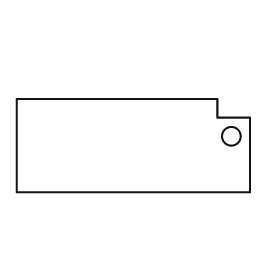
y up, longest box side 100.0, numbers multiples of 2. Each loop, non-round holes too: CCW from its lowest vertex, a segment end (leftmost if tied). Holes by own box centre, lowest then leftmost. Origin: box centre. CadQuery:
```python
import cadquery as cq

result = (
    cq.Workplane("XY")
    .moveTo(-50.0, -20.0)
    .lineTo(50.0, -20.0)
    .lineTo(50.0, 12.0)
    .lineTo(36.0, 12.0)
    .lineTo(36.0, 20.0)
    .lineTo(-50.0, 20.0)
    .close()
    .moveTo(42.0, 4.0)
    .circle(4.0)
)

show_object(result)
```